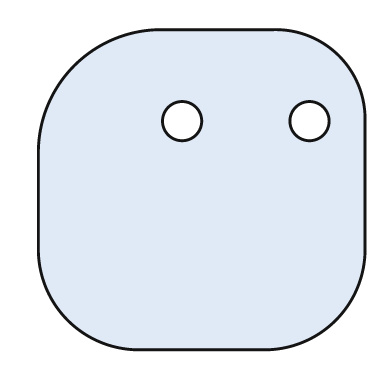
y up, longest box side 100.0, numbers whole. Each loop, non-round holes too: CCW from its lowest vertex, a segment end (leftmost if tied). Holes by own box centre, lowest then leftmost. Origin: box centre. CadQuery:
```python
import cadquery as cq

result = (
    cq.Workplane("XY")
    .moveTo(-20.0, -49.0)
    .lineTo(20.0, -49.0)
    .threePointArc((41.0, -40.0), (50.0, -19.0))
    .lineTo(50.0, 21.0)
    .threePointArc((42.0, 41.0), (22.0, 49.0))
    .lineTo(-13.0, 49.0)
    .threePointArc((-39.0, 38.0), (-50.0, 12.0))
    .lineTo(-50.0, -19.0)
    .threePointArc((-41.0, -40.0), (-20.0, -49.0))
    .close()
    .moveTo(-6.0, 21.0)
    .circle(6.0)
    .moveTo(33.0, 21.0)
    .circle(6.0)
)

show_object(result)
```